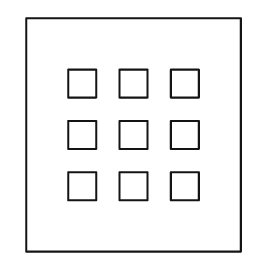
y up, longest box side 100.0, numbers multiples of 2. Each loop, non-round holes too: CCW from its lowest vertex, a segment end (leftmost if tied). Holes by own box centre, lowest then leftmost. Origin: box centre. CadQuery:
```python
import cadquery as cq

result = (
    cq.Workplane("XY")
    .moveTo(-46.0, -50.0)
    .lineTo(46.0, -50.0)
    .lineTo(46.0, 50.0)
    .lineTo(-46.0, 50.0)
    .close()
    .moveTo(-28.0, -28.0)
    .lineTo(-16.0, -28.0)
    .lineTo(-16.0, -16.0)
    .lineTo(-28.0, -16.0)
    .close()
    .moveTo(-6.0, -28.0)
    .lineTo(6.0, -28.0)
    .lineTo(6.0, -16.0)
    .lineTo(-6.0, -16.0)
    .close()
    .moveTo(16.0, -28.0)
    .lineTo(28.0, -28.0)
    .lineTo(28.0, -16.0)
    .lineTo(16.0, -16.0)
    .close()
    .moveTo(-28.0, -6.0)
    .lineTo(-16.0, -6.0)
    .lineTo(-16.0, 6.0)
    .lineTo(-28.0, 6.0)
    .close()
    .moveTo(-6.0, -6.0)
    .lineTo(6.0, -6.0)
    .lineTo(6.0, 6.0)
    .lineTo(-6.0, 6.0)
    .close()
    .moveTo(16.0, -6.0)
    .lineTo(28.0, -6.0)
    .lineTo(28.0, 6.0)
    .lineTo(16.0, 6.0)
    .close()
    .moveTo(-28.0, 16.0)
    .lineTo(-16.0, 16.0)
    .lineTo(-16.0, 28.0)
    .lineTo(-28.0, 28.0)
    .close()
    .moveTo(-6.0, 16.0)
    .lineTo(6.0, 16.0)
    .lineTo(6.0, 28.0)
    .lineTo(-6.0, 28.0)
    .close()
    .moveTo(16.0, 16.0)
    .lineTo(28.0, 16.0)
    .lineTo(28.0, 28.0)
    .lineTo(16.0, 28.0)
    .close()
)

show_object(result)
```